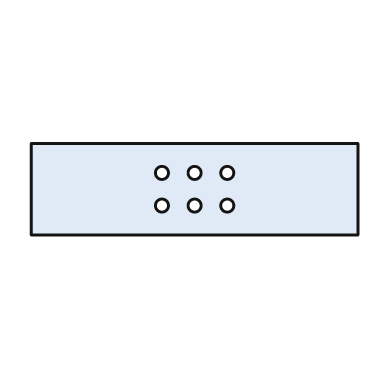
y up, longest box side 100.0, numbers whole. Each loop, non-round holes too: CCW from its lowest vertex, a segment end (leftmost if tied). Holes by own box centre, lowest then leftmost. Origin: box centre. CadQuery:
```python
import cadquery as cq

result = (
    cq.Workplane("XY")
    .moveTo(-50.0, -14.0)
    .lineTo(50.0, -14.0)
    .lineTo(50.0, 14.0)
    .lineTo(-50.0, 14.0)
    .close()
    .moveTo(-10.0, -5.0)
    .circle(2.0)
    .moveTo(0.0, -5.0)
    .circle(2.0)
    .moveTo(10.0, -5.0)
    .circle(2.0)
    .moveTo(-10.0, 5.0)
    .circle(2.0)
    .moveTo(0.0, 5.0)
    .circle(2.0)
    .moveTo(10.0, 5.0)
    .circle(2.0)
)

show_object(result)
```